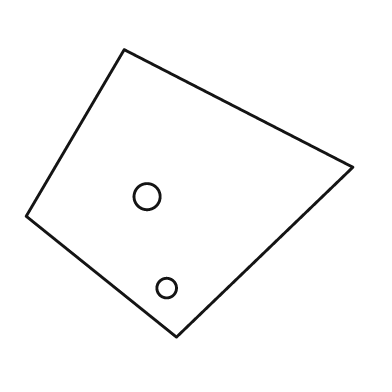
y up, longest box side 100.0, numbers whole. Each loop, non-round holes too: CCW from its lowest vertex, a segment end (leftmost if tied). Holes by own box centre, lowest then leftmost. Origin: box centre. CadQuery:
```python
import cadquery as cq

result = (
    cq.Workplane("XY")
    .moveTo(-4.0, -44.0)
    .lineTo(50.0, 8.0)
    .lineTo(-20.0, 44.0)
    .lineTo(-50.0, -7.0)
    .close()
    .moveTo(-7.0, -29.0)
    .circle(3.0)
    .moveTo(-13.0, -1.0)
    .circle(4.0)
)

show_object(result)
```